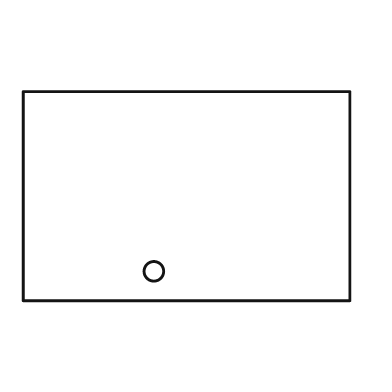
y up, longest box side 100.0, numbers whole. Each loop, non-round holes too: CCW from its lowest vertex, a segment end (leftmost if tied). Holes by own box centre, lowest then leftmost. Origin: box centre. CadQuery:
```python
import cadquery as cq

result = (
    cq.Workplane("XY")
    .moveTo(-50.0, -32.0)
    .lineTo(50.0, -32.0)
    .lineTo(50.0, 32.0)
    .lineTo(-50.0, 32.0)
    .close()
    .moveTo(-10.0, -23.0)
    .circle(3.0)
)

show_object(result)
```